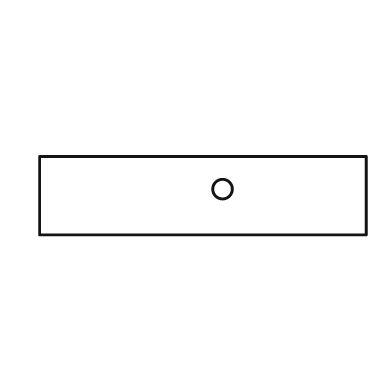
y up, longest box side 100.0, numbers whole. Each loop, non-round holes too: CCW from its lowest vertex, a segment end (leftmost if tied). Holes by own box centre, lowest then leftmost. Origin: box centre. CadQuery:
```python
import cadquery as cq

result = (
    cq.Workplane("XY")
    .moveTo(-50.0, -12.0)
    .lineTo(50.0, -12.0)
    .lineTo(50.0, 12.0)
    .lineTo(-50.0, 12.0)
    .close()
    .moveTo(6.0, 2.0)
    .circle(3.0)
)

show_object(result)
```